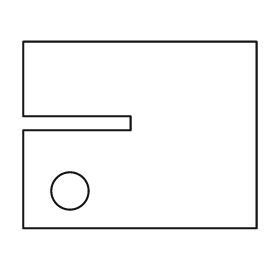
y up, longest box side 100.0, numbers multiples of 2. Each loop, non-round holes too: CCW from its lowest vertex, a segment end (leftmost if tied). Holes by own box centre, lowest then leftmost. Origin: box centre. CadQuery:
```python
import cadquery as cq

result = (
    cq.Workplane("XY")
    .moveTo(-50.0, -40.0)
    .lineTo(50.0, -40.0)
    .lineTo(50.0, 40.0)
    .lineTo(-50.0, 40.0)
    .lineTo(-50.0, 8.0)
    .lineTo(-4.0, 8.0)
    .lineTo(-4.0, 2.0)
    .lineTo(-50.0, 2.0)
    .close()
    .moveTo(-30.0, -24.0)
    .circle(8.0)
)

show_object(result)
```